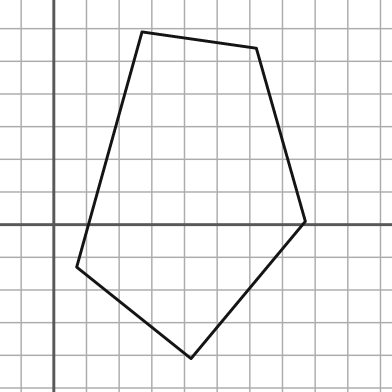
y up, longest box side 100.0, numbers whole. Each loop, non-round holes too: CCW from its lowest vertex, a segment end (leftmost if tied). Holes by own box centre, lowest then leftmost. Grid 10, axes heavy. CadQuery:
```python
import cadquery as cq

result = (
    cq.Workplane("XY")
    .moveTo(42.0, -41.0)
    .lineTo(77.0, 1.0)
    .lineTo(62.0, 54.0)
    .lineTo(27.0, 59.0)
    .lineTo(7.0, -13.0)
    .close()
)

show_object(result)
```